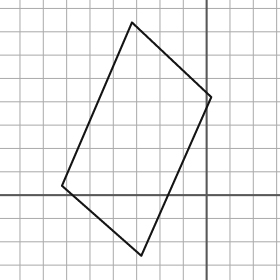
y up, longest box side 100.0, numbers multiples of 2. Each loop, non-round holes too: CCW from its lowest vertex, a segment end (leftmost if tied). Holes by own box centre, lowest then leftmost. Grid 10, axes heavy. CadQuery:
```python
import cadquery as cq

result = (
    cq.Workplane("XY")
    .moveTo(-28.0, -26.0)
    .lineTo(2.0, 42.0)
    .lineTo(-32.0, 74.0)
    .lineTo(-62.0, 4.0)
    .close()
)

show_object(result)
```